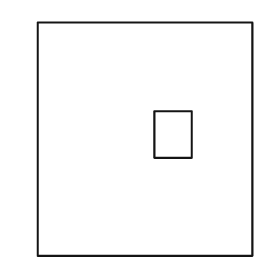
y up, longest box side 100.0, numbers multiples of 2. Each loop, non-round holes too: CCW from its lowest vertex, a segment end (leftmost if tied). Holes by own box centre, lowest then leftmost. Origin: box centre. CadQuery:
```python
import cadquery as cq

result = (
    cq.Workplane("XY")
    .moveTo(-46.0, -50.0)
    .lineTo(46.0, -50.0)
    .lineTo(46.0, 50.0)
    .lineTo(-46.0, 50.0)
    .close()
    .moveTo(4.0, -8.0)
    .lineTo(20.0, -8.0)
    .lineTo(20.0, 12.0)
    .lineTo(4.0, 12.0)
    .close()
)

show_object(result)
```